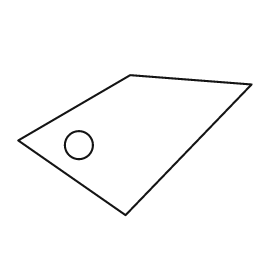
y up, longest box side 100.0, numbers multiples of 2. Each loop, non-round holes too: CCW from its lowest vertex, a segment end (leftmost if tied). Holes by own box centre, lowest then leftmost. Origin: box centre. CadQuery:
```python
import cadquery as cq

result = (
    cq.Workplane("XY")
    .moveTo(-4.0, -30.0)
    .lineTo(50.0, 26.0)
    .lineTo(-2.0, 30.0)
    .lineTo(-50.0, 2.0)
    .close()
    .moveTo(-24.0, 0.0)
    .circle(6.0)
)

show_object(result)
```